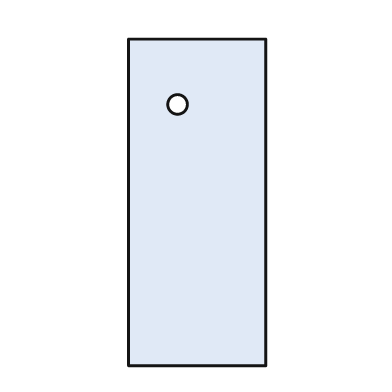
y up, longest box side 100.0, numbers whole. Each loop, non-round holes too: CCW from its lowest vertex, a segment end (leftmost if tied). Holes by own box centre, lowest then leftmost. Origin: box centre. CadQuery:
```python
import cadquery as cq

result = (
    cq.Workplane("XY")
    .moveTo(-21.0, -50.0)
    .lineTo(21.0, -50.0)
    .lineTo(21.0, 50.0)
    .lineTo(-21.0, 50.0)
    .close()
    .moveTo(-6.0, 30.0)
    .circle(3.0)
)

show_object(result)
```